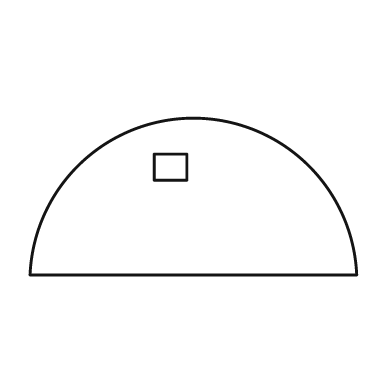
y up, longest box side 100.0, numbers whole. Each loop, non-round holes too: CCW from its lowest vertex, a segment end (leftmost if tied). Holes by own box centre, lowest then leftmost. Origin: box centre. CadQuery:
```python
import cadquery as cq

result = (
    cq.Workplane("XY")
    .moveTo(-50.0, -24.0)
    .lineTo(50.0, -24.0)
    .threePointArc((0.0, 24.0), (-50.0, -24.0))
    .close()
    .moveTo(-12.0, 5.0)
    .lineTo(-2.0, 5.0)
    .lineTo(-2.0, 13.0)
    .lineTo(-12.0, 13.0)
    .close()
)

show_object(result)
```